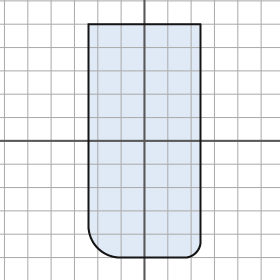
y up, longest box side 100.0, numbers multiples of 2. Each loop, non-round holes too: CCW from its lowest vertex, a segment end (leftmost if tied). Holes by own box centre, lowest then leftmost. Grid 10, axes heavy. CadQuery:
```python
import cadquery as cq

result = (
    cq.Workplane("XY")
    .moveTo(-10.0, -50.0)
    .lineTo(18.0, -50.0)
    .threePointArc((22.0, -48.0), (24.0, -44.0))
    .lineTo(24.0, 50.0)
    .lineTo(-24.0, 50.0)
    .lineTo(-24.0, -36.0)
    .threePointArc((-20.0, -46.0), (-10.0, -50.0))
    .close()
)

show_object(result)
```